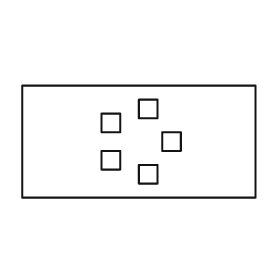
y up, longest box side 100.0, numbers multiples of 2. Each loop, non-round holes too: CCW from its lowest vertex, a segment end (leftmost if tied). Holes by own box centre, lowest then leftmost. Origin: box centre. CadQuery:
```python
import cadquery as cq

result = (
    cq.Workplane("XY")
    .moveTo(-50.0, -24.0)
    .lineTo(50.0, -24.0)
    .lineTo(50.0, 24.0)
    .lineTo(-50.0, 24.0)
    .close()
    .moveTo(0.0, -18.0)
    .lineTo(8.0, -18.0)
    .lineTo(8.0, -10.0)
    .lineTo(0.0, -10.0)
    .close()
    .moveTo(-16.0, -12.0)
    .lineTo(-8.0, -12.0)
    .lineTo(-8.0, -4.0)
    .lineTo(-16.0, -4.0)
    .close()
    .moveTo(10.0, -4.0)
    .lineTo(18.0, -4.0)
    .lineTo(18.0, 4.0)
    .lineTo(10.0, 4.0)
    .close()
    .moveTo(-16.0, 4.0)
    .lineTo(-8.0, 4.0)
    .lineTo(-8.0, 12.0)
    .lineTo(-16.0, 12.0)
    .close()
    .moveTo(0.0, 10.0)
    .lineTo(8.0, 10.0)
    .lineTo(8.0, 18.0)
    .lineTo(0.0, 18.0)
    .close()
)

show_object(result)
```